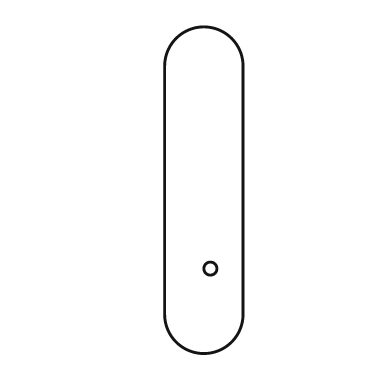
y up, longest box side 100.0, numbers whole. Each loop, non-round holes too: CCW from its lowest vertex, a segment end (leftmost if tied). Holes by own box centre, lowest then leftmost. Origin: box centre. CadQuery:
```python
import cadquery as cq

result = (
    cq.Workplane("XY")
    .moveTo(-12.0, -38.0)
    .threePointArc((0.0, -50.0), (12.0, -38.0))
    .lineTo(12.0, 38.0)
    .threePointArc((0.0, 50.0), (-12.0, 38.0))
    .close()
    .moveTo(2.0, -24.0)
    .circle(2.0)
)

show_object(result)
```